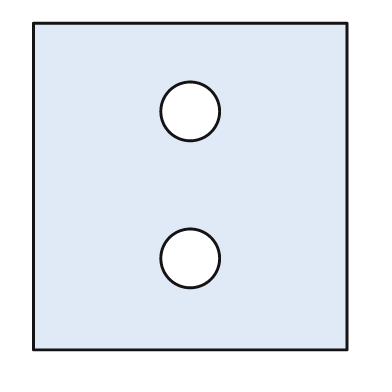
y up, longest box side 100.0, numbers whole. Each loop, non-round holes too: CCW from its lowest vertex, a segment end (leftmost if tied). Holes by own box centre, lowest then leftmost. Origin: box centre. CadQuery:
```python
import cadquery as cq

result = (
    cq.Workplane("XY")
    .moveTo(-48.0, -50.0)
    .lineTo(48.0, -50.0)
    .lineTo(48.0, 50.0)
    .lineTo(-48.0, 50.0)
    .close()
    .moveTo(0.0, -22.0)
    .circle(9.0)
    .moveTo(0.0, 23.0)
    .circle(9.0)
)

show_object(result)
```